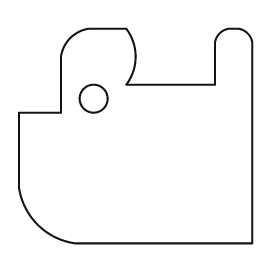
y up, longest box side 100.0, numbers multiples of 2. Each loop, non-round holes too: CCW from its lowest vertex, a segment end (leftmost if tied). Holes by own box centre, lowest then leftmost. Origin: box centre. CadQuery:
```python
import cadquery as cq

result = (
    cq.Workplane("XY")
    .moveTo(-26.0, -46.0)
    .lineTo(50.0, -46.0)
    .lineTo(50.0, 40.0)
    .threePointArc((48.0, 44.0), (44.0, 46.0))
    .lineTo(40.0, 46.0)
    .threePointArc((36.0, 44.0), (34.0, 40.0))
    .lineTo(34.0, 22.0)
    .lineTo(-4.0, 22.0)
    .threePointArc((0.0, 34.0), (-4.0, 46.0))
    .lineTo(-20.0, 46.0)
    .threePointArc((-28.0, 42.0), (-32.0, 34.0))
    .lineTo(-32.0, 10.0)
    .lineTo(-50.0, 10.0)
    .lineTo(-50.0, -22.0)
    .threePointArc((-42.0, -38.0), (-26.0, -46.0))
    .close()
    .moveTo(-18.0, 16.0)
    .circle(6.0)
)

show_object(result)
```